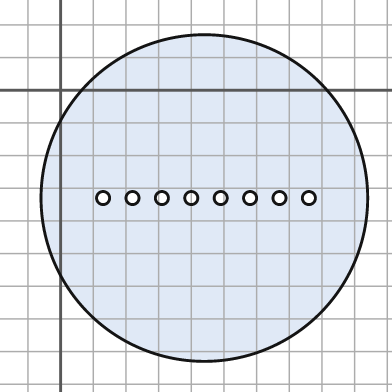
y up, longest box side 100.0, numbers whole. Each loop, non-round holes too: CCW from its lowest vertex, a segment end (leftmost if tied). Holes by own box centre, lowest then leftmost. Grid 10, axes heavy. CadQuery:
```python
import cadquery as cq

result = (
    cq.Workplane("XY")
    .moveTo(44.0, -33.0)
    .circle(50.0)
    .moveTo(13.0, -33.0)
    .circle(2.0)
    .moveTo(22.0, -33.0)
    .circle(2.0)
    .moveTo(31.0, -33.0)
    .circle(2.0)
    .moveTo(40.0, -33.0)
    .circle(2.0)
    .moveTo(49.0, -33.0)
    .circle(2.0)
    .moveTo(58.0, -33.0)
    .circle(2.0)
    .moveTo(67.0, -33.0)
    .circle(2.0)
    .moveTo(76.0, -33.0)
    .circle(2.0)
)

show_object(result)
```